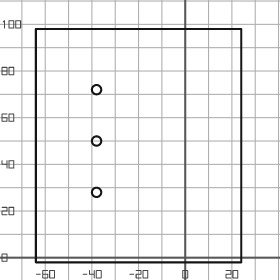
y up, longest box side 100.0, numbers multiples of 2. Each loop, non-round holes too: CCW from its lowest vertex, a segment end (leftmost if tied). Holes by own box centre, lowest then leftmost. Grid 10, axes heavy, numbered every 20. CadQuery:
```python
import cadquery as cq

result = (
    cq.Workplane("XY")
    .moveTo(-64.0, -2.0)
    .lineTo(24.0, -2.0)
    .lineTo(24.0, 98.0)
    .lineTo(-64.0, 98.0)
    .close()
    .moveTo(-38.0, 28.0)
    .circle(2.0)
    .moveTo(-38.0, 50.0)
    .circle(2.0)
    .moveTo(-38.0, 72.0)
    .circle(2.0)
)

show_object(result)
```